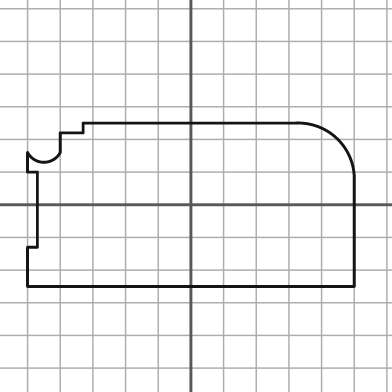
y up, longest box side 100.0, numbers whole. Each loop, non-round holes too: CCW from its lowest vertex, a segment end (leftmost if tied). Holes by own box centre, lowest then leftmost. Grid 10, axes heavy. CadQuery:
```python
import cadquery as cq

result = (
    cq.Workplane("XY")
    .moveTo(-50.0, -25.0)
    .lineTo(50.0, -25.0)
    .lineTo(50.0, 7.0)
    .threePointArc((45.0, 20.0), (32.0, 25.0))
    .lineTo(-33.0, 25.0)
    .lineTo(-33.0, 22.0)
    .lineTo(-40.0, 22.0)
    .lineTo(-40.0, 16.0)
    .threePointArc((-45.0, 13.0), (-50.0, 16.0))
    .lineTo(-50.0, 10.0)
    .lineTo(-47.0, 10.0)
    .lineTo(-47.0, -13.0)
    .lineTo(-50.0, -13.0)
    .close()
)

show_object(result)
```